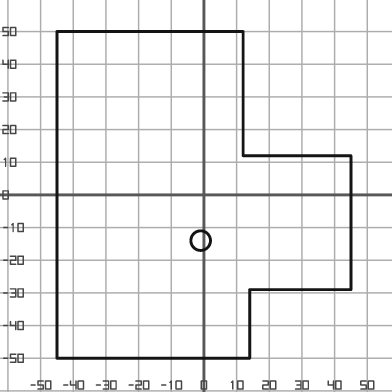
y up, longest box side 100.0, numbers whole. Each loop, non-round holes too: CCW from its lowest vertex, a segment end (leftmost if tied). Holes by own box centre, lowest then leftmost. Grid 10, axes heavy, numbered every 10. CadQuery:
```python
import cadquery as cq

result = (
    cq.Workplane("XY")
    .moveTo(-45.0, -50.0)
    .lineTo(14.0, -50.0)
    .lineTo(14.0, -29.0)
    .lineTo(45.0, -29.0)
    .lineTo(45.0, 12.0)
    .lineTo(12.0, 12.0)
    .lineTo(12.0, 50.0)
    .lineTo(-45.0, 50.0)
    .close()
    .moveTo(-1.0, -14.0)
    .circle(3.0)
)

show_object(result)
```